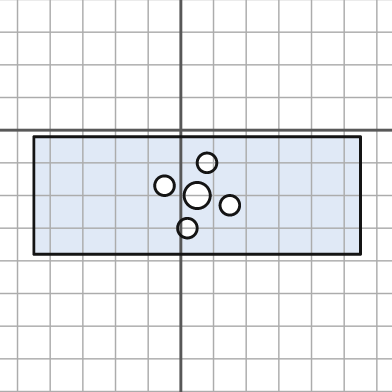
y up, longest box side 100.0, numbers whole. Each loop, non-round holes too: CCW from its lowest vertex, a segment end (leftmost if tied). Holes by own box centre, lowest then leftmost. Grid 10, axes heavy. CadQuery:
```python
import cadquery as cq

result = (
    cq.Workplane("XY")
    .moveTo(-45.0, -38.0)
    .lineTo(55.0, -38.0)
    .lineTo(55.0, -2.0)
    .lineTo(-45.0, -2.0)
    .close()
    .moveTo(2.0, -30.0)
    .circle(3.0)
    .moveTo(15.0, -23.0)
    .circle(3.0)
    .moveTo(5.0, -20.0)
    .circle(4.0)
    .moveTo(-5.0, -17.0)
    .circle(3.0)
    .moveTo(8.0, -10.0)
    .circle(3.0)
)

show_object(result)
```